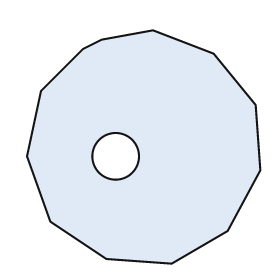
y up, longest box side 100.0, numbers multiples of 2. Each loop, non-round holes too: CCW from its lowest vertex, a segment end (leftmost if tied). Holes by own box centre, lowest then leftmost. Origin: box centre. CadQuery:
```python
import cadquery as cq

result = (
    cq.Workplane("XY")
    .moveTo(12.0, -50.0)
    .lineTo(36.0, -36.0)
    .lineTo(50.0, -10.0)
    .lineTo(48.0, 18.0)
    .lineTo(30.0, 40.0)
    .lineTo(4.0, 50.0)
    .lineTo(-18.0, 46.0)
    .lineTo(-26.0, 42.0)
    .lineTo(-44.0, 24.0)
    .lineTo(-50.0, -4.0)
    .lineTo(-40.0, -32.0)
    .lineTo(-16.0, -48.0)
    .close()
    .moveTo(-12.0, -4.0)
    .circle(10.0)
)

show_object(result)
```